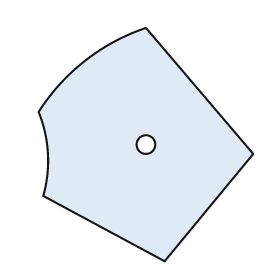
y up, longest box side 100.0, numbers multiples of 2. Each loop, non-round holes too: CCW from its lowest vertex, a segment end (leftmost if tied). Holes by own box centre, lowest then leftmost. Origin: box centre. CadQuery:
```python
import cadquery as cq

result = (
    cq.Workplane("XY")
    .moveTo(8.0, -50.0)
    .lineTo(46.0, -4.0)
    .lineTo(0.0, 50.0)
    .threePointArc((-26.0, 36.0), (-46.0, 14.0))
    .threePointArc((-42.0, -4.0), (-44.0, -22.0))
    .close()
    .moveTo(0.0, 0.0)
    .circle(4.0)
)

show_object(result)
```